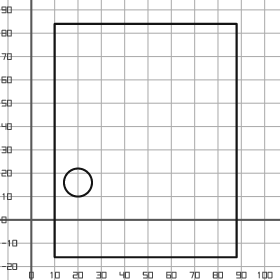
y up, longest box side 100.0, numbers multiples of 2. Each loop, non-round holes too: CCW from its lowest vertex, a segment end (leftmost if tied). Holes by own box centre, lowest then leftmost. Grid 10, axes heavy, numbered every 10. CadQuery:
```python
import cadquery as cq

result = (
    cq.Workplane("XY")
    .moveTo(10.0, -16.0)
    .lineTo(88.0, -16.0)
    .lineTo(88.0, 84.0)
    .lineTo(10.0, 84.0)
    .close()
    .moveTo(20.0, 16.0)
    .circle(6.0)
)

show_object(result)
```